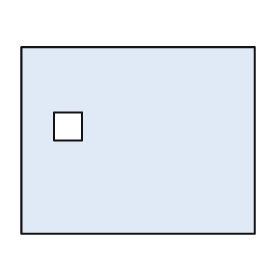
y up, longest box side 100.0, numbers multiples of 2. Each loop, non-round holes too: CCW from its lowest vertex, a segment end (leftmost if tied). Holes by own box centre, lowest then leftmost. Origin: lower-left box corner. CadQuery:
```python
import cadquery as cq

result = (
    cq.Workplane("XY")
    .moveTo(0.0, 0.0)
    .lineTo(100.0, 0.0)
    .lineTo(100.0, 80.0)
    .lineTo(0.0, 80.0)
    .close()
    .moveTo(14.0, 40.0)
    .lineTo(26.0, 40.0)
    .lineTo(26.0, 52.0)
    .lineTo(14.0, 52.0)
    .close()
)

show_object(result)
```